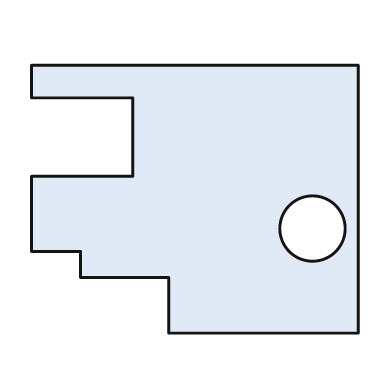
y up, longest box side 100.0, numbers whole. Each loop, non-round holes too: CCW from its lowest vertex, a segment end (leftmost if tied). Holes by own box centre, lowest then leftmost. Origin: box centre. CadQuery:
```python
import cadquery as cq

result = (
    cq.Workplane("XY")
    .moveTo(-8.0, -41.0)
    .lineTo(50.0, -41.0)
    .lineTo(50.0, 41.0)
    .lineTo(-50.0, 41.0)
    .lineTo(-50.0, 31.0)
    .lineTo(-19.0, 31.0)
    .lineTo(-19.0, 7.0)
    .lineTo(-50.0, 7.0)
    .lineTo(-50.0, -16.0)
    .lineTo(-35.0, -16.0)
    .lineTo(-35.0, -24.0)
    .lineTo(-8.0, -24.0)
    .close()
    .moveTo(36.0, -9.0)
    .circle(10.0)
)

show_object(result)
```